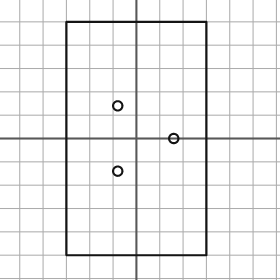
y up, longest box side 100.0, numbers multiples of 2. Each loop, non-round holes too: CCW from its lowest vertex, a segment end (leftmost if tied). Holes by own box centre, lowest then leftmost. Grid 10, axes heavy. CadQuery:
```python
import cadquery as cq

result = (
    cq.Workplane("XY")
    .moveTo(-30.0, -50.0)
    .lineTo(30.0, -50.0)
    .lineTo(30.0, 50.0)
    .lineTo(-30.0, 50.0)
    .close()
    .moveTo(-8.0, -14.0)
    .circle(2.0)
    .moveTo(16.0, 0.0)
    .circle(2.0)
    .moveTo(-8.0, 14.0)
    .circle(2.0)
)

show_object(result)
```